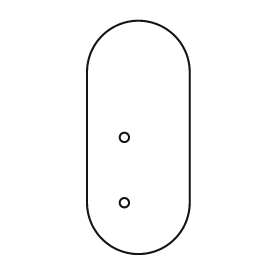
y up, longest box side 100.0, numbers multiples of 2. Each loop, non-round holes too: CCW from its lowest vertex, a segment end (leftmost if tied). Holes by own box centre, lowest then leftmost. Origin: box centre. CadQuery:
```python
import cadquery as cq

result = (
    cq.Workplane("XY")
    .moveTo(-22.0, -28.0)
    .threePointArc((0.0, -50.0), (22.0, -28.0))
    .lineTo(22.0, 28.0)
    .threePointArc((0.0, 50.0), (-22.0, 28.0))
    .close()
    .moveTo(-6.0, -28.0)
    .circle(2.0)
    .moveTo(-6.0, 0.0)
    .circle(2.0)
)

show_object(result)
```